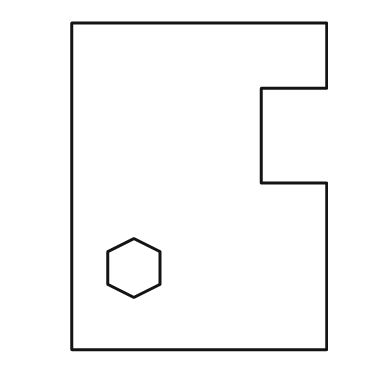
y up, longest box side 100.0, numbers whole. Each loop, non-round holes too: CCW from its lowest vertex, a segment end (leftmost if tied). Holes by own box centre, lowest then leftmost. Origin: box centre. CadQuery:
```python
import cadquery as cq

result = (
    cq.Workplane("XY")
    .moveTo(-39.0, -50.0)
    .lineTo(39.0, -50.0)
    .lineTo(39.0, 1.0)
    .lineTo(19.0, 1.0)
    .lineTo(19.0, 30.0)
    .lineTo(39.0, 30.0)
    .lineTo(39.0, 50.0)
    .lineTo(-39.0, 50.0)
    .close()
    .moveTo(-20.0, -34.0)
    .lineTo(-12.0, -30.0)
    .lineTo(-12.0, -20.0)
    .lineTo(-20.0, -16.0)
    .lineTo(-28.0, -20.0)
    .lineTo(-28.0, -30.0)
    .close()
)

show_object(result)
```